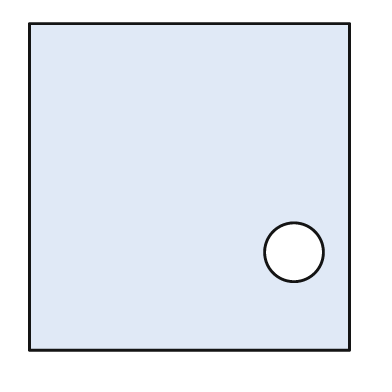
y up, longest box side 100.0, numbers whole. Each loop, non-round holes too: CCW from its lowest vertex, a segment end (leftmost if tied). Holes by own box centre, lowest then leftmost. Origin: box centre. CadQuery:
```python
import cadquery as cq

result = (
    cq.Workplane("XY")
    .moveTo(-49.0, -50.0)
    .lineTo(49.0, -50.0)
    .lineTo(49.0, 50.0)
    .lineTo(-49.0, 50.0)
    .close()
    .moveTo(32.0, -20.0)
    .circle(9.0)
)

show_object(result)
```